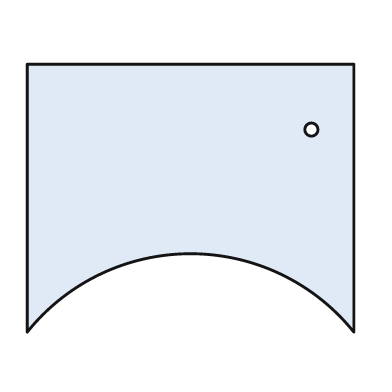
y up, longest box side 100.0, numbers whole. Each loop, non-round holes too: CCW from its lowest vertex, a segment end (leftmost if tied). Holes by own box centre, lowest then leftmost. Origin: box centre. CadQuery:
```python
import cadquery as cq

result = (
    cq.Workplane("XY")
    .moveTo(-50.0, -41.0)
    .threePointArc((0.0, -17.0), (50.0, -41.0))
    .lineTo(50.0, 41.0)
    .lineTo(-50.0, 41.0)
    .close()
    .moveTo(37.0, 21.0)
    .circle(2.0)
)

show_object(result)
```